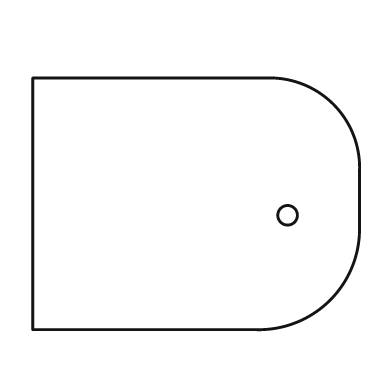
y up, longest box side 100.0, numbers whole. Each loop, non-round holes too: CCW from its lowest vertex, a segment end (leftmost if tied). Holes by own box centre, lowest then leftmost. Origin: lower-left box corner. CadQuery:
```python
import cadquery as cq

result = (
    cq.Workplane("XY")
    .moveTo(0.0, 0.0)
    .lineTo(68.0, 0.0)
    .threePointArc((91.0, 9.0), (100.0, 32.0))
    .lineTo(100.0, 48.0)
    .threePointArc((92.0, 69.0), (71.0, 77.0))
    .lineTo(0.0, 77.0)
    .close()
    .moveTo(78.0, 35.0)
    .circle(3.0)
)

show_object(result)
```